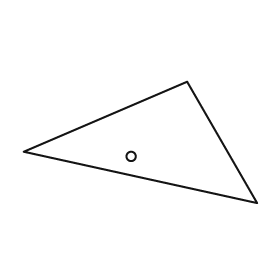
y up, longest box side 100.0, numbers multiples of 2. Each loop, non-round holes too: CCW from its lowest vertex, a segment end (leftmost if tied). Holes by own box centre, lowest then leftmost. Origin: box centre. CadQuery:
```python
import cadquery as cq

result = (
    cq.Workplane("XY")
    .moveTo(50.0, -26.0)
    .lineTo(20.0, 26.0)
    .lineTo(-50.0, -4.0)
    .close()
    .moveTo(-4.0, -6.0)
    .circle(2.0)
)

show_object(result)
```